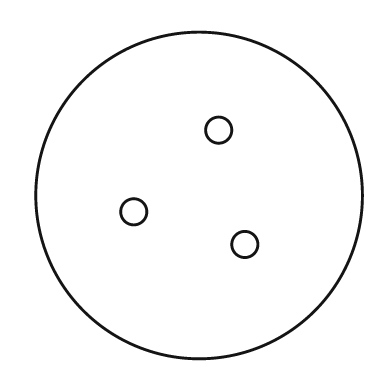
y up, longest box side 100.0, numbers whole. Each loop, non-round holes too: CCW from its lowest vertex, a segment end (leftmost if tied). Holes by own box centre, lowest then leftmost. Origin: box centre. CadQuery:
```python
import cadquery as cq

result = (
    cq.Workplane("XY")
    .moveTo(0.0, 0.0)
    .circle(50.0)
    .moveTo(14.0, -15.0)
    .circle(4.0)
    .moveTo(-20.0, -5.0)
    .circle(4.0)
    .moveTo(6.0, 20.0)
    .circle(4.0)
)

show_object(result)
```